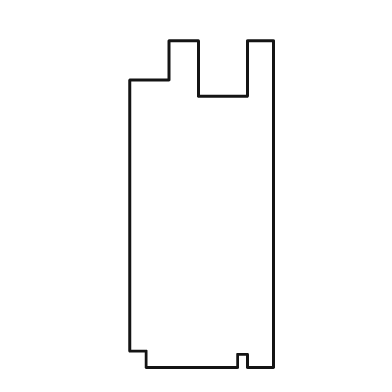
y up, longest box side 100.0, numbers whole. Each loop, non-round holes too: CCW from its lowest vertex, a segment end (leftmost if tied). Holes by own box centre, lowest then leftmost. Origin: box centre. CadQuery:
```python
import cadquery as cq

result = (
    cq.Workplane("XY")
    .moveTo(-17.0, -50.0)
    .lineTo(11.0, -50.0)
    .lineTo(11.0, -46.0)
    .lineTo(14.0, -46.0)
    .lineTo(14.0, -50.0)
    .lineTo(22.0, -50.0)
    .lineTo(22.0, 50.0)
    .lineTo(14.0, 50.0)
    .lineTo(14.0, 33.0)
    .lineTo(-1.0, 33.0)
    .lineTo(-1.0, 50.0)
    .lineTo(-10.0, 50.0)
    .lineTo(-10.0, 38.0)
    .lineTo(-22.0, 38.0)
    .lineTo(-22.0, -45.0)
    .lineTo(-17.0, -45.0)
    .close()
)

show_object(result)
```